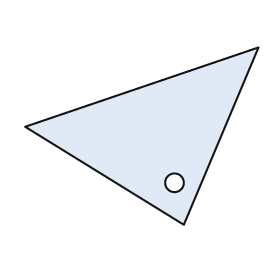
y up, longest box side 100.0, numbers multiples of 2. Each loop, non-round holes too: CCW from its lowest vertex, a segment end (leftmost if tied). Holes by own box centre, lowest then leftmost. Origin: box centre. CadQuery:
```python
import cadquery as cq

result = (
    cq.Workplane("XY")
    .moveTo(18.0, -38.0)
    .lineTo(50.0, 38.0)
    .lineTo(-50.0, 4.0)
    .close()
    .moveTo(14.0, -20.0)
    .circle(4.0)
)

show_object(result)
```